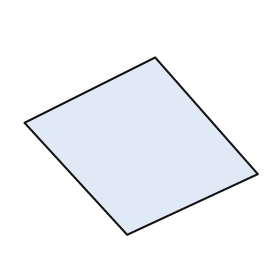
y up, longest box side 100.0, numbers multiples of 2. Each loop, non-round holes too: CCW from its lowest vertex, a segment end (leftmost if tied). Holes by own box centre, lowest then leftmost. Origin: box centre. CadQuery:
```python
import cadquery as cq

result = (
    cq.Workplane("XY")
    .moveTo(-6.0, -38.0)
    .lineTo(50.0, -12.0)
    .lineTo(6.0, 38.0)
    .lineTo(-50.0, 10.0)
    .close()
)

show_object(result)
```